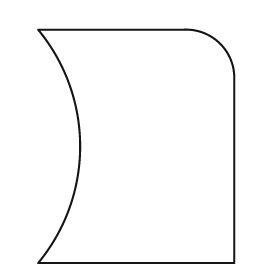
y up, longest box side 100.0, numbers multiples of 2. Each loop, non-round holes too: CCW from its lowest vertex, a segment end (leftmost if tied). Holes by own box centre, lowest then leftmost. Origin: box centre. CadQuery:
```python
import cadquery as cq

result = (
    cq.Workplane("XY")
    .moveTo(-42.0, -50.0)
    .lineTo(42.0, -50.0)
    .lineTo(42.0, 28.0)
    .threePointArc((36.0, 44.0), (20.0, 50.0))
    .lineTo(-42.0, 50.0)
    .threePointArc((-24.0, 0.0), (-42.0, -50.0))
    .close()
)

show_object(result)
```